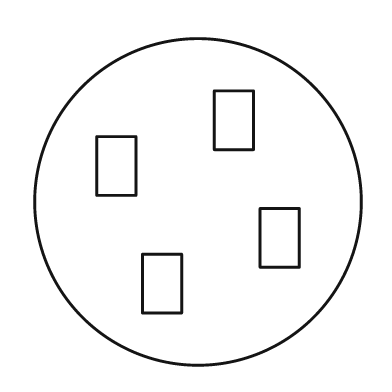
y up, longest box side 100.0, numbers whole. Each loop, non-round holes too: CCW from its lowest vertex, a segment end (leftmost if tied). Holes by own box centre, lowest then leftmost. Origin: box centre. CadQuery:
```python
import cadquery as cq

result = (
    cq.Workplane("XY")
    .moveTo(0.0, 0.0)
    .circle(50.0)
    .moveTo(-17.0, -34.0)
    .lineTo(-5.0, -34.0)
    .lineTo(-5.0, -16.0)
    .lineTo(-17.0, -16.0)
    .close()
    .moveTo(19.0, -20.0)
    .lineTo(31.0, -20.0)
    .lineTo(31.0, -2.0)
    .lineTo(19.0, -2.0)
    .close()
    .moveTo(-31.0, 2.0)
    .lineTo(-19.0, 2.0)
    .lineTo(-19.0, 20.0)
    .lineTo(-31.0, 20.0)
    .close()
    .moveTo(5.0, 16.0)
    .lineTo(17.0, 16.0)
    .lineTo(17.0, 34.0)
    .lineTo(5.0, 34.0)
    .close()
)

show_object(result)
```